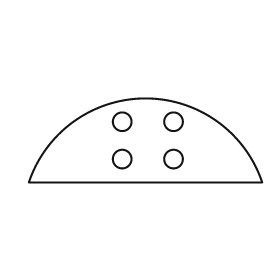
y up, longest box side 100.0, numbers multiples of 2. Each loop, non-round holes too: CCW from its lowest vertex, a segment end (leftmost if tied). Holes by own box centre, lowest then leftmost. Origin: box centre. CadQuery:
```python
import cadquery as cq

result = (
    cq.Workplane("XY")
    .moveTo(-50.0, -18.0)
    .lineTo(50.0, -18.0)
    .threePointArc((0.0, 18.0), (-50.0, -18.0))
    .close()
    .moveTo(-10.0, -8.0)
    .circle(4.0)
    .moveTo(12.0, -8.0)
    .circle(4.0)
    .moveTo(-10.0, 8.0)
    .circle(4.0)
    .moveTo(12.0, 8.0)
    .circle(4.0)
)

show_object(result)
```